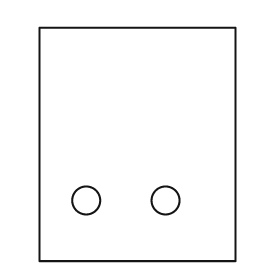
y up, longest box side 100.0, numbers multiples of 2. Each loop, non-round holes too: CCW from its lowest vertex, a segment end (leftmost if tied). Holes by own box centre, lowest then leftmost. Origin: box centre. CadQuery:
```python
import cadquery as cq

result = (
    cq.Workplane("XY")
    .moveTo(-42.0, -50.0)
    .lineTo(42.0, -50.0)
    .lineTo(42.0, 50.0)
    .lineTo(-42.0, 50.0)
    .close()
    .moveTo(-22.0, -24.0)
    .circle(6.0)
    .moveTo(12.0, -24.0)
    .circle(6.0)
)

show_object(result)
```